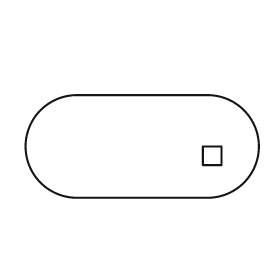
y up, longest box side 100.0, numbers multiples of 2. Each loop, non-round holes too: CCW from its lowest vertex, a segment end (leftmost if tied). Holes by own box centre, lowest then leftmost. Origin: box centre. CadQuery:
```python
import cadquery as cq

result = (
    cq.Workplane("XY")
    .moveTo(-28.0, -22.0)
    .lineTo(28.0, -22.0)
    .threePointArc((50.0, 0.0), (28.0, 22.0))
    .lineTo(-28.0, 22.0)
    .threePointArc((-50.0, 0.0), (-28.0, -22.0))
    .close()
    .moveTo(26.0, -8.0)
    .lineTo(34.0, -8.0)
    .lineTo(34.0, 0.0)
    .lineTo(26.0, 0.0)
    .close()
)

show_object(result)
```